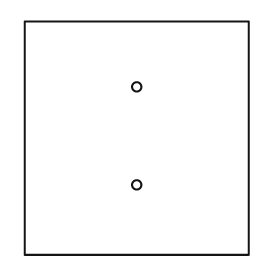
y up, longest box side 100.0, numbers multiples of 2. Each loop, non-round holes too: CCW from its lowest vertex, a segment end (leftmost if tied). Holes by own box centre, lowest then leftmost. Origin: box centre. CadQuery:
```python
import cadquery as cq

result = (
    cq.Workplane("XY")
    .moveTo(-48.0, -50.0)
    .lineTo(48.0, -50.0)
    .lineTo(48.0, 50.0)
    .lineTo(-48.0, 50.0)
    .close()
    .moveTo(0.0, -20.0)
    .circle(2.0)
    .moveTo(0.0, 22.0)
    .circle(2.0)
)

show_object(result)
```